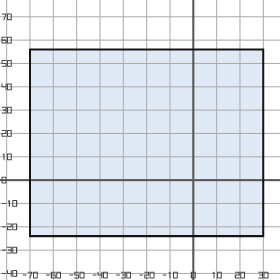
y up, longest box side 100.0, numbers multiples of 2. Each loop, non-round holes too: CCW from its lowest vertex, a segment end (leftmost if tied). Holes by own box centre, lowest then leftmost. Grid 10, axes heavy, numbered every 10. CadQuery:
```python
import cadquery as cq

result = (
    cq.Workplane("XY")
    .moveTo(-70.0, -24.0)
    .lineTo(30.0, -24.0)
    .lineTo(30.0, 56.0)
    .lineTo(-70.0, 56.0)
    .close()
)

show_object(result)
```